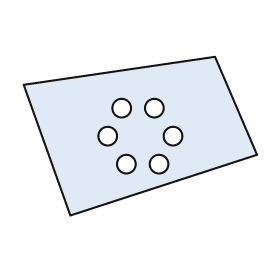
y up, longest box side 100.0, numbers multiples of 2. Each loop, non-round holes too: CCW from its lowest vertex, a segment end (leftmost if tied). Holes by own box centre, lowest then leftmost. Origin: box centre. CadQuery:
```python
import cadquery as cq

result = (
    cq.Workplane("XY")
    .moveTo(-30.0, -34.0)
    .lineTo(50.0, -8.0)
    .lineTo(32.0, 34.0)
    .lineTo(-50.0, 22.0)
    .close()
    .moveTo(-6.0, -12.0)
    .circle(4.0)
    .moveTo(8.0, -12.0)
    .circle(4.0)
    .moveTo(-14.0, 0.0)
    .circle(4.0)
    .moveTo(14.0, 0.0)
    .circle(4.0)
    .moveTo(-8.0, 12.0)
    .circle(4.0)
    .moveTo(6.0, 12.0)
    .circle(4.0)
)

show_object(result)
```